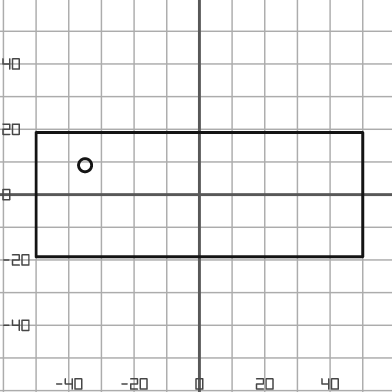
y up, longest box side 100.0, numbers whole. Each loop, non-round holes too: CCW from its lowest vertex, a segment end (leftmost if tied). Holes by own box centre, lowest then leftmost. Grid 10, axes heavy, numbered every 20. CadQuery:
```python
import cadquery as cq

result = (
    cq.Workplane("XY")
    .moveTo(-50.0, -19.0)
    .lineTo(50.0, -19.0)
    .lineTo(50.0, 19.0)
    .lineTo(-50.0, 19.0)
    .close()
    .moveTo(-35.0, 9.0)
    .circle(2.0)
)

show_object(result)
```